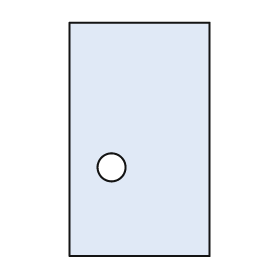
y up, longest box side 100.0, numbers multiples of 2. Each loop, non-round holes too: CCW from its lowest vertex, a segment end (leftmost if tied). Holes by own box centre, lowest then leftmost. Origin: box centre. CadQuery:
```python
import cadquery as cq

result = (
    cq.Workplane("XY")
    .moveTo(-30.0, -50.0)
    .lineTo(30.0, -50.0)
    .lineTo(30.0, 50.0)
    .lineTo(-30.0, 50.0)
    .close()
    .moveTo(-12.0, -12.0)
    .circle(6.0)
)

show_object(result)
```